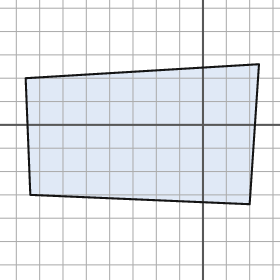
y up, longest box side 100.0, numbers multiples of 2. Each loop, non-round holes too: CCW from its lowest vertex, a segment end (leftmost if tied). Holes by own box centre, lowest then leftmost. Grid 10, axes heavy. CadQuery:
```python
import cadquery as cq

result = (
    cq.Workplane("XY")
    .moveTo(20.0, -34.0)
    .lineTo(24.0, 26.0)
    .lineTo(-76.0, 20.0)
    .lineTo(-74.0, -30.0)
    .close()
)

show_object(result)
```